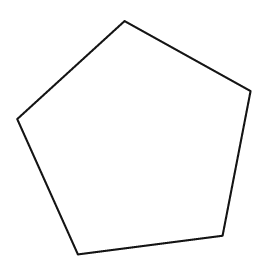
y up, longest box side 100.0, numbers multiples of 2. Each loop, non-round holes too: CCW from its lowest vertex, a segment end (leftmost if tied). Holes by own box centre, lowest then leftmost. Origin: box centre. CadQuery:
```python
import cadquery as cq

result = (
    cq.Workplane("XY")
    .moveTo(-24.0, -50.0)
    .lineTo(38.0, -42.0)
    .lineTo(50.0, 20.0)
    .lineTo(-4.0, 50.0)
    .lineTo(-50.0, 8.0)
    .close()
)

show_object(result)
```